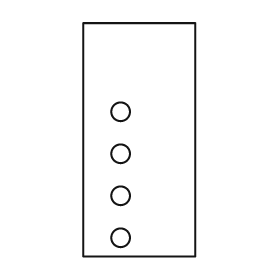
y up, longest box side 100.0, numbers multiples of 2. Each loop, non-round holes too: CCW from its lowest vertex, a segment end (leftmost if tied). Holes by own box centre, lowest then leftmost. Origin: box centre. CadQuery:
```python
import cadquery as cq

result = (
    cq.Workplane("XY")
    .moveTo(-24.0, -50.0)
    .lineTo(24.0, -50.0)
    .lineTo(24.0, 50.0)
    .lineTo(-24.0, 50.0)
    .close()
    .moveTo(-8.0, -42.0)
    .circle(4.0)
    .moveTo(-8.0, -24.0)
    .circle(4.0)
    .moveTo(-8.0, -6.0)
    .circle(4.0)
    .moveTo(-8.0, 12.0)
    .circle(4.0)
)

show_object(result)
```